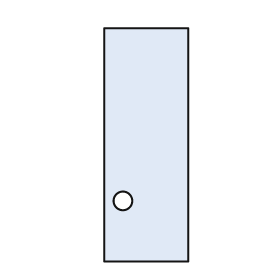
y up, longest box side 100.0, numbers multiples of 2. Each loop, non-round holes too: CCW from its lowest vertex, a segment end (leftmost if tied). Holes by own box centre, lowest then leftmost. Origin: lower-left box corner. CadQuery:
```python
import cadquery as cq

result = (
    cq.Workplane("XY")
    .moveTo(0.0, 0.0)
    .lineTo(36.0, 0.0)
    .lineTo(36.0, 100.0)
    .lineTo(0.0, 100.0)
    .close()
    .moveTo(8.0, 26.0)
    .circle(4.0)
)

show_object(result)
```